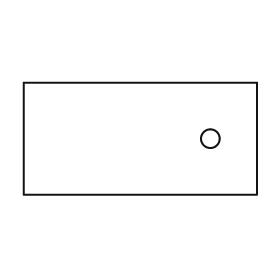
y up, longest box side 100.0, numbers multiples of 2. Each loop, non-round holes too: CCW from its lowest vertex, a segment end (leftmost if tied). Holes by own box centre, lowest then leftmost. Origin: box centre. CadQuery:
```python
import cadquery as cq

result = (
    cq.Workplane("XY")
    .moveTo(-50.0, -24.0)
    .lineTo(50.0, -24.0)
    .lineTo(50.0, 24.0)
    .lineTo(-50.0, 24.0)
    .close()
    .moveTo(30.0, 0.0)
    .circle(4.0)
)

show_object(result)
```